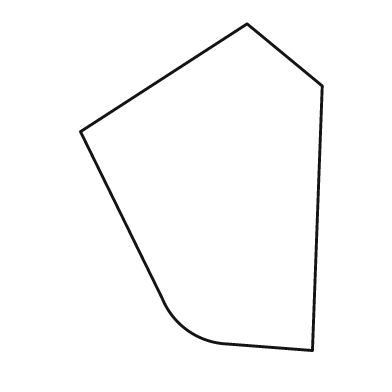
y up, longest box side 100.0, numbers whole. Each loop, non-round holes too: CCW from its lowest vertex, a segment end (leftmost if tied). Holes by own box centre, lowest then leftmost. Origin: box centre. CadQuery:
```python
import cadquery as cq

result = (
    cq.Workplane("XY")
    .moveTo(34.0, -50.0)
    .lineTo(37.0, 31.0)
    .lineTo(14.0, 50.0)
    .lineTo(-37.0, 17.0)
    .lineTo(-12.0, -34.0)
    .threePointArc((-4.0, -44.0), (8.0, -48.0))
    .close()
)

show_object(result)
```